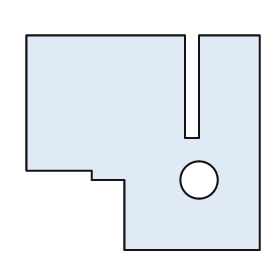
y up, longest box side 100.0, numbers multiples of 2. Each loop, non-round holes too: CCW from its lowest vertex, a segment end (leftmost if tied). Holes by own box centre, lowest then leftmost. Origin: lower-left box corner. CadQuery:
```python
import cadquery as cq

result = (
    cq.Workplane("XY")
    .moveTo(42.0, 0.0)
    .lineTo(100.0, 0.0)
    .lineTo(100.0, 92.0)
    .lineTo(74.0, 92.0)
    .lineTo(74.0, 48.0)
    .lineTo(68.0, 48.0)
    .lineTo(68.0, 92.0)
    .lineTo(0.0, 92.0)
    .lineTo(0.0, 34.0)
    .lineTo(28.0, 34.0)
    .lineTo(28.0, 30.0)
    .lineTo(42.0, 30.0)
    .close()
    .moveTo(74.0, 30.0)
    .circle(8.0)
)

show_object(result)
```